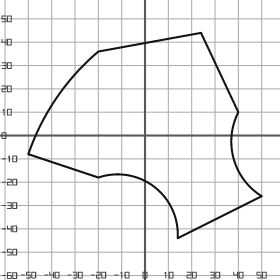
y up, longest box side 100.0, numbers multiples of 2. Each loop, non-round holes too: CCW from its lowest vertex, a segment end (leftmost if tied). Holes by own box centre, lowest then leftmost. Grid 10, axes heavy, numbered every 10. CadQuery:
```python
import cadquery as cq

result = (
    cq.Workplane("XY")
    .moveTo(14.0, -44.0)
    .lineTo(50.0, -26.0)
    .threePointArc((38.0, -10.0), (40.0, 10.0))
    .lineTo(24.0, 44.0)
    .lineTo(-20.0, 36.0)
    .threePointArc((-38.0, 16.0), (-50.0, -8.0))
    .lineTo(-20.0, -18.0)
    .threePointArc((4.0, -22.0), (14.0, -44.0))
    .close()
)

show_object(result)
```